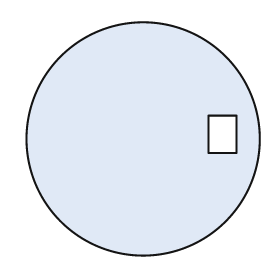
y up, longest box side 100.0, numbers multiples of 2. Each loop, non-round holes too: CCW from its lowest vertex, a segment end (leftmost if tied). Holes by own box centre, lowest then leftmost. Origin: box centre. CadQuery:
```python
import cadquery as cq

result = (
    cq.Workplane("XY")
    .moveTo(0.0, 0.0)
    .circle(50.0)
    .moveTo(28.0, -6.0)
    .lineTo(40.0, -6.0)
    .lineTo(40.0, 10.0)
    .lineTo(28.0, 10.0)
    .close()
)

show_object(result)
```